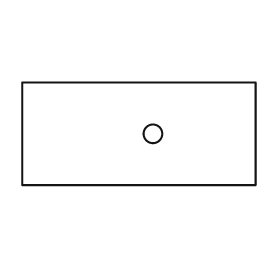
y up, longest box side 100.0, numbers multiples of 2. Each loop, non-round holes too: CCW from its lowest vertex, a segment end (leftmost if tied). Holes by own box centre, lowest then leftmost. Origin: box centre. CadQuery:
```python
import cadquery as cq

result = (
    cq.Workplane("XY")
    .moveTo(-50.0, -22.0)
    .lineTo(50.0, -22.0)
    .lineTo(50.0, 22.0)
    .lineTo(-50.0, 22.0)
    .close()
    .moveTo(6.0, 0.0)
    .circle(4.0)
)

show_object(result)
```